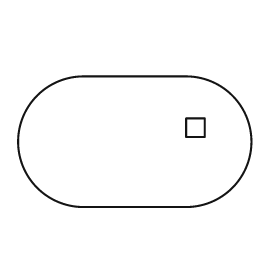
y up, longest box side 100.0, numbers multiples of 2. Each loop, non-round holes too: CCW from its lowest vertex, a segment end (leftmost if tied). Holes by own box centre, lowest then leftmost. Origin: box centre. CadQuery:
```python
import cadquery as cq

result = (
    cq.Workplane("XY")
    .moveTo(-22.0, -28.0)
    .lineTo(22.0, -28.0)
    .threePointArc((50.0, 0.0), (22.0, 28.0))
    .lineTo(-22.0, 28.0)
    .threePointArc((-50.0, 0.0), (-22.0, -28.0))
    .close()
    .moveTo(22.0, 2.0)
    .lineTo(30.0, 2.0)
    .lineTo(30.0, 10.0)
    .lineTo(22.0, 10.0)
    .close()
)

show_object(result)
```